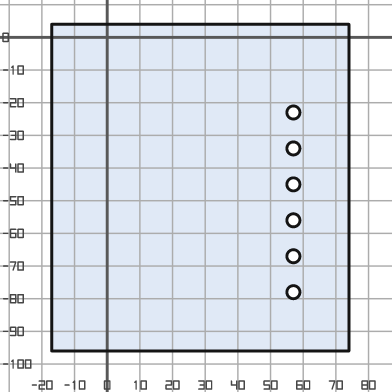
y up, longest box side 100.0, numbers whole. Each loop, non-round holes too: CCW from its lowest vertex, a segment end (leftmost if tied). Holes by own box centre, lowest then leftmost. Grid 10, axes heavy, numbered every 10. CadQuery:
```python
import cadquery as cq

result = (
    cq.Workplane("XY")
    .moveTo(-17.0, -96.0)
    .lineTo(74.0, -96.0)
    .lineTo(74.0, 4.0)
    .lineTo(-17.0, 4.0)
    .close()
    .moveTo(57.0, -78.0)
    .circle(2.0)
    .moveTo(57.0, -67.0)
    .circle(2.0)
    .moveTo(57.0, -56.0)
    .circle(2.0)
    .moveTo(57.0, -45.0)
    .circle(2.0)
    .moveTo(57.0, -34.0)
    .circle(2.0)
    .moveTo(57.0, -23.0)
    .circle(2.0)
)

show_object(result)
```